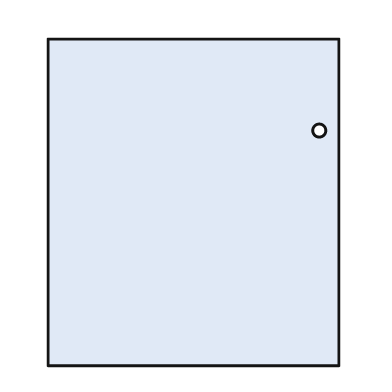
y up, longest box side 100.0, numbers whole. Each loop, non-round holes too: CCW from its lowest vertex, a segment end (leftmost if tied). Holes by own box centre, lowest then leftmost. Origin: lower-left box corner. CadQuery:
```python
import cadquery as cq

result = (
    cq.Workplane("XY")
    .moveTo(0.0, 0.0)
    .lineTo(89.0, 0.0)
    .lineTo(89.0, 100.0)
    .lineTo(0.0, 100.0)
    .close()
    .moveTo(83.0, 72.0)
    .circle(2.0)
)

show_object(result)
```